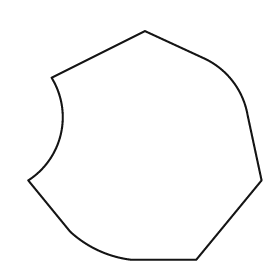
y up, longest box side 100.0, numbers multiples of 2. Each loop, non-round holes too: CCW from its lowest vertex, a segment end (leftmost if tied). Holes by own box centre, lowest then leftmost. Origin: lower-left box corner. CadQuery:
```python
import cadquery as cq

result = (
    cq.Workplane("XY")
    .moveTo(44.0, 0.0)
    .lineTo(72.0, 0.0)
    .lineTo(100.0, 34.0)
    .lineTo(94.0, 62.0)
    .threePointArc((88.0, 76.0), (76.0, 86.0))
    .lineTo(50.0, 98.0)
    .lineTo(10.0, 78.0)
    .threePointArc((14.0, 54.0), (0.0, 34.0))
    .lineTo(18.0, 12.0)
    .threePointArc((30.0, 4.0), (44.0, 0.0))
    .close()
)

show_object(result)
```